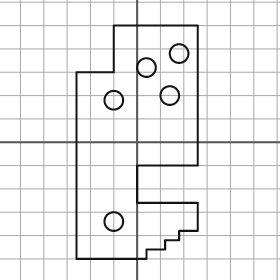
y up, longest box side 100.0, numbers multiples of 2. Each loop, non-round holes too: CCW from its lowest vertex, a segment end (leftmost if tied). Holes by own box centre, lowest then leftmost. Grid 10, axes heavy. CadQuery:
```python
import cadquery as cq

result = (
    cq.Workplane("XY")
    .moveTo(-26.0, -50.0)
    .lineTo(4.0, -50.0)
    .lineTo(4.0, -46.0)
    .lineTo(12.0, -46.0)
    .lineTo(12.0, -42.0)
    .lineTo(18.0, -42.0)
    .lineTo(18.0, -38.0)
    .lineTo(26.0, -38.0)
    .lineTo(26.0, -26.0)
    .lineTo(0.0, -26.0)
    .lineTo(0.0, -10.0)
    .lineTo(26.0, -10.0)
    .lineTo(26.0, 50.0)
    .lineTo(-10.0, 50.0)
    .lineTo(-10.0, 30.0)
    .lineTo(-26.0, 30.0)
    .close()
    .moveTo(-10.0, -34.0)
    .circle(4.0)
    .moveTo(-10.0, 18.0)
    .circle(4.0)
    .moveTo(14.0, 20.0)
    .circle(4.0)
    .moveTo(4.0, 32.0)
    .circle(4.0)
    .moveTo(18.0, 38.0)
    .circle(4.0)
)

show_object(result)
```